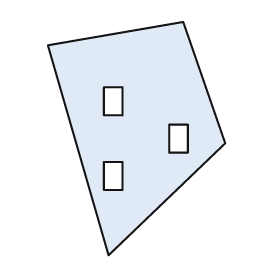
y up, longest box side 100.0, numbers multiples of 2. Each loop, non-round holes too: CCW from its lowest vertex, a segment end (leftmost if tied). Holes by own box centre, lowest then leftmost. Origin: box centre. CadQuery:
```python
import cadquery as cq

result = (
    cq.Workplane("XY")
    .moveTo(-12.0, -50.0)
    .lineTo(38.0, -2.0)
    .lineTo(20.0, 50.0)
    .lineTo(-38.0, 40.0)
    .close()
    .moveTo(-14.0, -22.0)
    .lineTo(-6.0, -22.0)
    .lineTo(-6.0, -10.0)
    .lineTo(-14.0, -10.0)
    .close()
    .moveTo(14.0, -6.0)
    .lineTo(22.0, -6.0)
    .lineTo(22.0, 6.0)
    .lineTo(14.0, 6.0)
    .close()
    .moveTo(-14.0, 10.0)
    .lineTo(-6.0, 10.0)
    .lineTo(-6.0, 22.0)
    .lineTo(-14.0, 22.0)
    .close()
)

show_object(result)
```